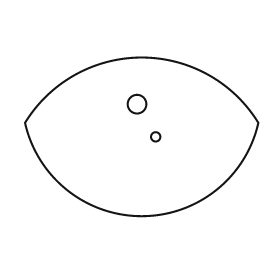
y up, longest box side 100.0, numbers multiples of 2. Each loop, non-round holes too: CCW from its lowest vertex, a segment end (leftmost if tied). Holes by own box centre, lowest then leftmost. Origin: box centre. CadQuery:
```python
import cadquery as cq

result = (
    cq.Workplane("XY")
    .moveTo(-50.0, 6.0)
    .threePointArc((0.0, -34.0), (50.0, 6.0))
    .threePointArc((0.0, 34.0), (-50.0, 6.0))
    .close()
    .moveTo(6.0, 0.0)
    .circle(2.0)
    .moveTo(-2.0, 14.0)
    .circle(4.0)
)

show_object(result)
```